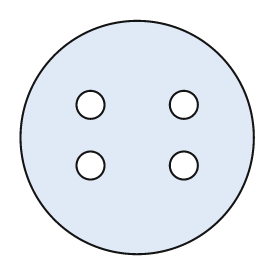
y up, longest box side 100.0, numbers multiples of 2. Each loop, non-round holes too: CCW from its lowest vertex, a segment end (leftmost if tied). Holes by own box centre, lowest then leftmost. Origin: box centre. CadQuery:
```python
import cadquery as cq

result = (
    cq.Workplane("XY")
    .moveTo(0.0, 0.0)
    .circle(50.0)
    .moveTo(-20.0, -12.0)
    .circle(6.0)
    .moveTo(20.0, -12.0)
    .circle(6.0)
    .moveTo(-20.0, 14.0)
    .circle(6.0)
    .moveTo(20.0, 14.0)
    .circle(6.0)
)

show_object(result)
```